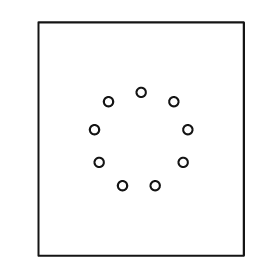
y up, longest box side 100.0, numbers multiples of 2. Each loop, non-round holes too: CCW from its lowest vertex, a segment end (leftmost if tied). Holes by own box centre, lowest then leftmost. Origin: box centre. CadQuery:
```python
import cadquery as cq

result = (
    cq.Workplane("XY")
    .moveTo(-44.0, -50.0)
    .lineTo(44.0, -50.0)
    .lineTo(44.0, 50.0)
    .lineTo(-44.0, 50.0)
    .close()
    .moveTo(-8.0, -20.0)
    .circle(2.0)
    .moveTo(6.0, -20.0)
    .circle(2.0)
    .moveTo(-18.0, -10.0)
    .circle(2.0)
    .moveTo(18.0, -10.0)
    .circle(2.0)
    .moveTo(-20.0, 4.0)
    .circle(2.0)
    .moveTo(20.0, 4.0)
    .circle(2.0)
    .moveTo(-14.0, 16.0)
    .circle(2.0)
    .moveTo(14.0, 16.0)
    .circle(2.0)
    .moveTo(0.0, 20.0)
    .circle(2.0)
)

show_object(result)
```